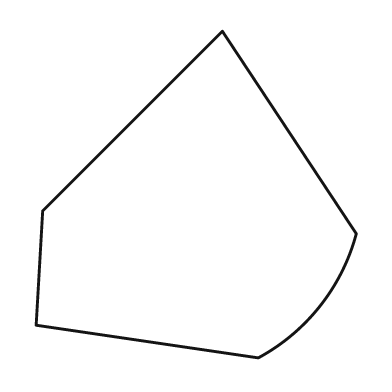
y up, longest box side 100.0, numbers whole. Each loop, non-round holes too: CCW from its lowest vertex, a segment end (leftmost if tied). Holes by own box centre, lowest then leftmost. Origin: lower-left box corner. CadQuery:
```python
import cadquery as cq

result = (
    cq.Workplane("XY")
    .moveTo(68.0, 0.0)
    .threePointArc((87.0, 16.0), (98.0, 38.0))
    .lineTo(57.0, 100.0)
    .lineTo(2.0, 45.0)
    .lineTo(0.0, 10.0)
    .close()
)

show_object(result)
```